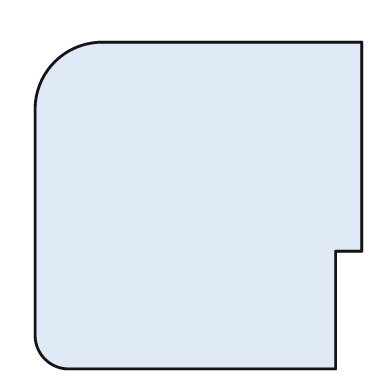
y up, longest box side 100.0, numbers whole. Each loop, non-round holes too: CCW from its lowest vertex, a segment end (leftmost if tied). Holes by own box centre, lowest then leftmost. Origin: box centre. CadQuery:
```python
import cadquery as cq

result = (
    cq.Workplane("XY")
    .moveTo(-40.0, -50.0)
    .lineTo(42.0, -50.0)
    .lineTo(42.0, -14.0)
    .lineTo(50.0, -14.0)
    .lineTo(50.0, 50.0)
    .lineTo(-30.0, 50.0)
    .threePointArc((-44.0, 44.0), (-50.0, 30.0))
    .lineTo(-50.0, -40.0)
    .threePointArc((-47.0, -47.0), (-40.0, -50.0))
    .close()
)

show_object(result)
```